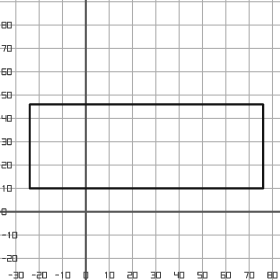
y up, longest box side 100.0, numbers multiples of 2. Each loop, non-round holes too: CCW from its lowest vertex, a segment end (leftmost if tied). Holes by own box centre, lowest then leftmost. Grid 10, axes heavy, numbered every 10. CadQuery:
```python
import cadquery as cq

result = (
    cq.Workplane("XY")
    .moveTo(-24.0, 10.0)
    .lineTo(76.0, 10.0)
    .lineTo(76.0, 46.0)
    .lineTo(-24.0, 46.0)
    .close()
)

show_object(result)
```